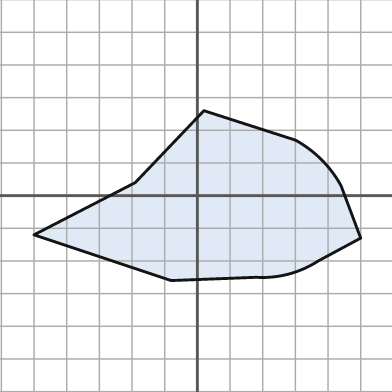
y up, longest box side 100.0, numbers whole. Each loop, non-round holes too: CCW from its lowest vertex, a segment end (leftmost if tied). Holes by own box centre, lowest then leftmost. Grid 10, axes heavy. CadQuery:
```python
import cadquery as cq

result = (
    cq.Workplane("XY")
    .moveTo(-8.0, -26.0)
    .lineTo(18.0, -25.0)
    .threePointArc((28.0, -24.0), (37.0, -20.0))
    .lineTo(50.0, -13.0)
    .lineTo(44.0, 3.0)
    .threePointArc((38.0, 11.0), (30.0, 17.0))
    .lineTo(2.0, 26.0)
    .lineTo(-19.0, 4.0)
    .lineTo(-50.0, -12.0)
    .close()
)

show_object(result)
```